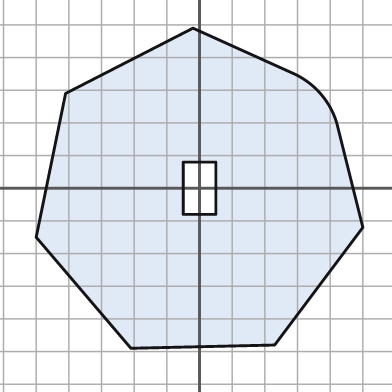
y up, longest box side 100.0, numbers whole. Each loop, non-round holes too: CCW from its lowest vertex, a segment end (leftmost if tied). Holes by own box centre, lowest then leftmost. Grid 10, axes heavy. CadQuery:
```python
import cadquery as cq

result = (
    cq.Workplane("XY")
    .moveTo(-21.0, -49.0)
    .lineTo(23.0, -48.0)
    .lineTo(50.0, -12.0)
    .lineTo(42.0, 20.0)
    .threePointArc((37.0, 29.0), (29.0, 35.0))
    .lineTo(-2.0, 49.0)
    .lineTo(-41.0, 29.0)
    .lineTo(-50.0, -15.0)
    .close()
    .moveTo(-5.0, -8.0)
    .lineTo(5.0, -8.0)
    .lineTo(5.0, 8.0)
    .lineTo(-5.0, 8.0)
    .close()
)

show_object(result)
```